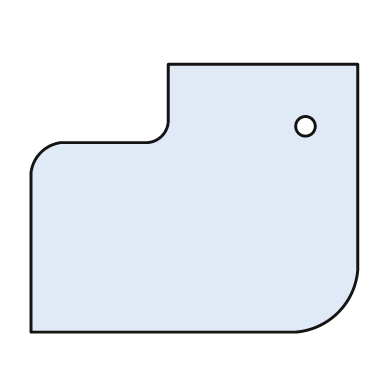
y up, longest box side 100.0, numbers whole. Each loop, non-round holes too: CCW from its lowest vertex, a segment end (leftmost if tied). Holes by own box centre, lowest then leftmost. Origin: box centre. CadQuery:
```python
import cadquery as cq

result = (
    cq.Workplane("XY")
    .moveTo(-50.0, -41.0)
    .lineTo(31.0, -41.0)
    .threePointArc((44.0, -35.0), (50.0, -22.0))
    .lineTo(50.0, 41.0)
    .lineTo(-8.0, 41.0)
    .lineTo(-8.0, 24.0)
    .threePointArc((-10.0, 19.0), (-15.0, 17.0))
    .lineTo(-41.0, 17.0)
    .threePointArc((-47.0, 14.0), (-50.0, 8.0))
    .close()
    .moveTo(34.0, 22.0)
    .circle(3.0)
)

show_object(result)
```